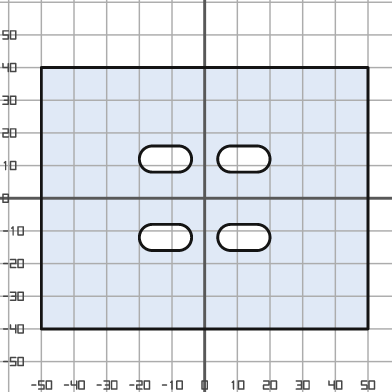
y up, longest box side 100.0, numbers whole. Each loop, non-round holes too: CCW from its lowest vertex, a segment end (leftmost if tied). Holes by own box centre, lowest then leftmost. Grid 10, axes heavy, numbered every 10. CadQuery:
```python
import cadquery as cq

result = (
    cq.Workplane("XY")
    .moveTo(-50.0, -40.0)
    .lineTo(50.0, -40.0)
    .lineTo(50.0, 40.0)
    .lineTo(-50.0, 40.0)
    .close()
    .moveTo(-16.0, -16.0)
    .lineTo(-8.0, -16.0)
    .threePointArc((-4.0, -12.0), (-8.0, -8.0))
    .lineTo(-16.0, -8.0)
    .threePointArc((-20.0, -12.0), (-16.0, -16.0))
    .close()
    .moveTo(8.0, -16.0)
    .lineTo(16.0, -16.0)
    .threePointArc((20.0, -12.0), (16.0, -8.0))
    .lineTo(8.0, -8.0)
    .threePointArc((4.0, -12.0), (8.0, -16.0))
    .close()
    .moveTo(-16.0, 8.0)
    .lineTo(-8.0, 8.0)
    .threePointArc((-4.0, 12.0), (-8.0, 16.0))
    .lineTo(-16.0, 16.0)
    .threePointArc((-20.0, 12.0), (-16.0, 8.0))
    .close()
    .moveTo(8.0, 8.0)
    .lineTo(16.0, 8.0)
    .threePointArc((20.0, 12.0), (16.0, 16.0))
    .lineTo(8.0, 16.0)
    .threePointArc((4.0, 12.0), (8.0, 8.0))
    .close()
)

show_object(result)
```